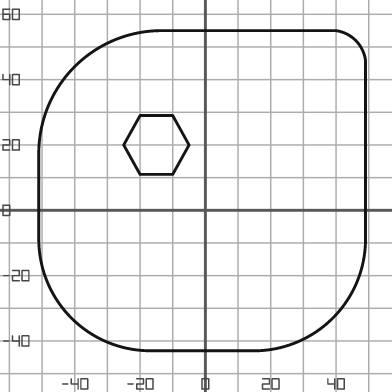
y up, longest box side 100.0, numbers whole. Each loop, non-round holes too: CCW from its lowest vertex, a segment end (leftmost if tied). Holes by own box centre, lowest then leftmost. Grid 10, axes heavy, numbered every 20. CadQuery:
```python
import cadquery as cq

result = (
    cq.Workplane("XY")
    .moveTo(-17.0, -43.0)
    .lineTo(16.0, -43.0)
    .threePointArc((39.0, -33.0), (49.0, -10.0))
    .lineTo(49.0, 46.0)
    .threePointArc((46.0, 52.0), (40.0, 55.0))
    .lineTo(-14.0, 55.0)
    .threePointArc((-40.0, 44.0), (-51.0, 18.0))
    .lineTo(-51.0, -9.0)
    .threePointArc((-41.0, -33.0), (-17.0, -43.0))
    .close()
    .moveTo(-20.0, 11.0)
    .lineTo(-10.0, 11.0)
    .lineTo(-5.0, 20.0)
    .lineTo(-10.0, 29.0)
    .lineTo(-20.0, 29.0)
    .lineTo(-25.0, 20.0)
    .close()
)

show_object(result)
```